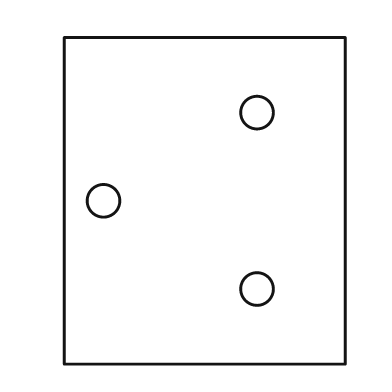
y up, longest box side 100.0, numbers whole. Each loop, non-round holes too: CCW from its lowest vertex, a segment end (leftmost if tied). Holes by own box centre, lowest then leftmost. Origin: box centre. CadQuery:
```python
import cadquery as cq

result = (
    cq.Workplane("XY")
    .moveTo(-43.0, -50.0)
    .lineTo(43.0, -50.0)
    .lineTo(43.0, 50.0)
    .lineTo(-43.0, 50.0)
    .close()
    .moveTo(16.0, -27.0)
    .circle(5.0)
    .moveTo(-31.0, 0.0)
    .circle(5.0)
    .moveTo(16.0, 27.0)
    .circle(5.0)
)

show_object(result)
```